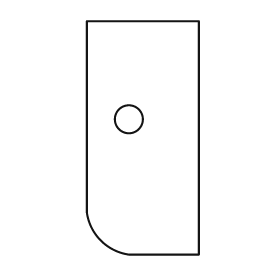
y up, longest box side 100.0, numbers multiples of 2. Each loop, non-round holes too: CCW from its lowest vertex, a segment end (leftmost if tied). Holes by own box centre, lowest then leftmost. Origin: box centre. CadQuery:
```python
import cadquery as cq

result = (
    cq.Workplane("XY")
    .moveTo(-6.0, -50.0)
    .lineTo(24.0, -50.0)
    .lineTo(24.0, 50.0)
    .lineTo(-24.0, 50.0)
    .lineTo(-24.0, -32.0)
    .threePointArc((-18.0, -44.0), (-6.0, -50.0))
    .close()
    .moveTo(-6.0, 8.0)
    .circle(6.0)
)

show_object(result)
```